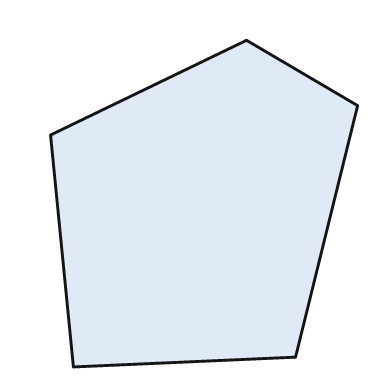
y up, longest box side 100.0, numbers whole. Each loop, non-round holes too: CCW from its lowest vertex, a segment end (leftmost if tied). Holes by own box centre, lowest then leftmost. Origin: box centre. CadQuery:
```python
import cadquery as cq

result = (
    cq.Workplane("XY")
    .moveTo(-40.0, -50.0)
    .lineTo(28.0, -47.0)
    .lineTo(47.0, 30.0)
    .lineTo(13.0, 50.0)
    .lineTo(-47.0, 21.0)
    .close()
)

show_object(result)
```